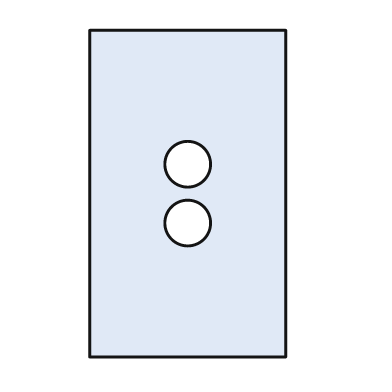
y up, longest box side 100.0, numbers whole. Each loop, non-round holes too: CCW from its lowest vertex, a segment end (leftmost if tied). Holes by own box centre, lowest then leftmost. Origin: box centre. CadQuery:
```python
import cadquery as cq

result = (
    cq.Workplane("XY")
    .moveTo(-30.0, -50.0)
    .lineTo(30.0, -50.0)
    .lineTo(30.0, 50.0)
    .lineTo(-30.0, 50.0)
    .close()
    .moveTo(0.0, -9.0)
    .circle(7.0)
    .moveTo(0.0, 9.0)
    .circle(7.0)
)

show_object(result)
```